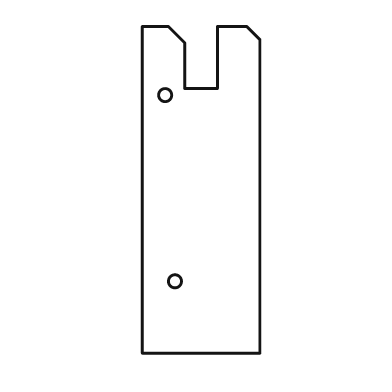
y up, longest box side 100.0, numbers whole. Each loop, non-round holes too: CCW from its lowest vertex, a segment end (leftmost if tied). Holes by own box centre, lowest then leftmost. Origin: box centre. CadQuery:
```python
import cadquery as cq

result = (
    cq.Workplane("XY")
    .moveTo(-18.0, -50.0)
    .lineTo(18.0, -50.0)
    .lineTo(18.0, 46.0)
    .lineTo(14.0, 50.0)
    .lineTo(5.0, 50.0)
    .lineTo(5.0, 31.0)
    .lineTo(-5.0, 31.0)
    .lineTo(-5.0, 45.0)
    .lineTo(-10.0, 50.0)
    .lineTo(-18.0, 50.0)
    .close()
    .moveTo(-8.0, -28.0)
    .circle(2.0)
    .moveTo(-11.0, 29.0)
    .circle(2.0)
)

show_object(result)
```